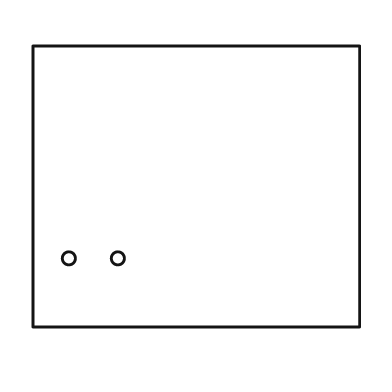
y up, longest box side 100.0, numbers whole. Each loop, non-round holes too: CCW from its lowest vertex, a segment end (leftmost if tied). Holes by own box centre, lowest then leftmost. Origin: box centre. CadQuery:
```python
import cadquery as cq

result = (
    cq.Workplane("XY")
    .moveTo(-50.0, -43.0)
    .lineTo(50.0, -43.0)
    .lineTo(50.0, 43.0)
    .lineTo(-50.0, 43.0)
    .close()
    .moveTo(-39.0, -22.0)
    .circle(2.0)
    .moveTo(-24.0, -22.0)
    .circle(2.0)
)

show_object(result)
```